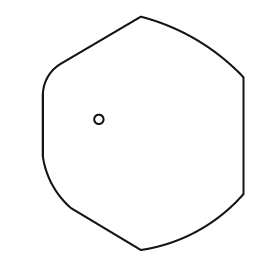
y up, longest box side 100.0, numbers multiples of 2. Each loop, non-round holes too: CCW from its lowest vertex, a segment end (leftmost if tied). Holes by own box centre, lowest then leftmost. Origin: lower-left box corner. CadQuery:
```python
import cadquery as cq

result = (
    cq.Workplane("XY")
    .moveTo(42.0, 0.0)
    .threePointArc((66.0, 8.0), (86.0, 24.0))
    .lineTo(86.0, 74.0)
    .threePointArc((66.0, 90.0), (42.0, 100.0))
    .lineTo(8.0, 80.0)
    .threePointArc((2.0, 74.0), (0.0, 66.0))
    .lineTo(0.0, 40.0)
    .threePointArc((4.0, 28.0), (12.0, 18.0))
    .close()
    .moveTo(24.0, 56.0)
    .circle(2.0)
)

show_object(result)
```